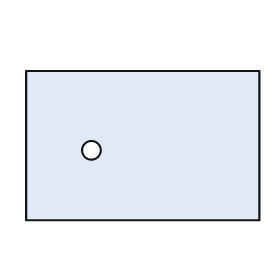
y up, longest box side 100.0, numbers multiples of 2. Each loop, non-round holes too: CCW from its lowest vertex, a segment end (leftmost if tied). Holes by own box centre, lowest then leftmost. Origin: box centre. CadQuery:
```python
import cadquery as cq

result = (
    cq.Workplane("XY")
    .moveTo(-50.0, -32.0)
    .lineTo(50.0, -32.0)
    .lineTo(50.0, 32.0)
    .lineTo(-50.0, 32.0)
    .close()
    .moveTo(-22.0, -2.0)
    .circle(4.0)
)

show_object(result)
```